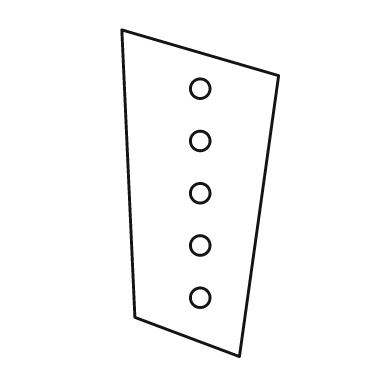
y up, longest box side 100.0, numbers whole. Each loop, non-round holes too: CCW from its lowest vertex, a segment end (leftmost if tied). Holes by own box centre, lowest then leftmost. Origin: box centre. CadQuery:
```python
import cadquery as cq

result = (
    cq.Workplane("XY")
    .moveTo(12.0, -50.0)
    .lineTo(24.0, 36.0)
    .lineTo(-24.0, 50.0)
    .lineTo(-20.0, -38.0)
    .close()
    .moveTo(0.0, -32.0)
    .circle(3.0)
    .moveTo(0.0, -16.0)
    .circle(3.0)
    .moveTo(0.0, 0.0)
    .circle(3.0)
    .moveTo(0.0, 16.0)
    .circle(3.0)
    .moveTo(0.0, 32.0)
    .circle(3.0)
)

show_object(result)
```